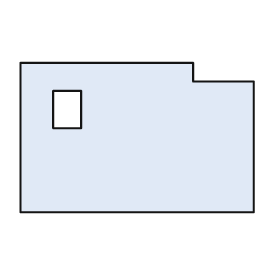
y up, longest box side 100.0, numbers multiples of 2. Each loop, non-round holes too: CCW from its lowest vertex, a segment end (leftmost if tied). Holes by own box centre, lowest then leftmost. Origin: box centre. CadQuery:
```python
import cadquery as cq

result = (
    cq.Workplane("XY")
    .moveTo(-50.0, -32.0)
    .lineTo(50.0, -32.0)
    .lineTo(50.0, 24.0)
    .lineTo(24.0, 24.0)
    .lineTo(24.0, 32.0)
    .lineTo(-50.0, 32.0)
    .close()
    .moveTo(-36.0, 4.0)
    .lineTo(-24.0, 4.0)
    .lineTo(-24.0, 20.0)
    .lineTo(-36.0, 20.0)
    .close()
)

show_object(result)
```